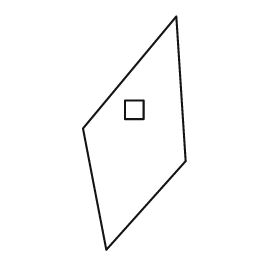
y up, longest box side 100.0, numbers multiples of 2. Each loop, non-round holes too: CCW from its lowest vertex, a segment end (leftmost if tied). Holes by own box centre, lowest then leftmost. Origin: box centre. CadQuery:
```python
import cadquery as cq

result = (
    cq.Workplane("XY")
    .moveTo(-12.0, -50.0)
    .lineTo(22.0, -12.0)
    .lineTo(18.0, 50.0)
    .lineTo(-22.0, 2.0)
    .close()
    .moveTo(-4.0, 6.0)
    .lineTo(4.0, 6.0)
    .lineTo(4.0, 14.0)
    .lineTo(-4.0, 14.0)
    .close()
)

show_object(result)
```